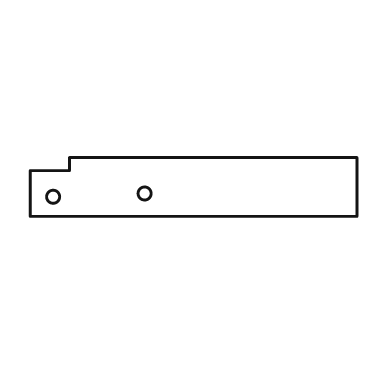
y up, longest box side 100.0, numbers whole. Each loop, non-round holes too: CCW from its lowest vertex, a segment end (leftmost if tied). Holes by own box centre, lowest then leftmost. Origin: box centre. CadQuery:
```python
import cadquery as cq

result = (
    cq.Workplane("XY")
    .moveTo(-50.0, -9.0)
    .lineTo(50.0, -9.0)
    .lineTo(50.0, 9.0)
    .lineTo(-38.0, 9.0)
    .lineTo(-38.0, 5.0)
    .lineTo(-50.0, 5.0)
    .close()
    .moveTo(-43.0, -3.0)
    .circle(2.0)
    .moveTo(-15.0, -2.0)
    .circle(2.0)
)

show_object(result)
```